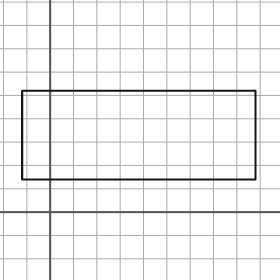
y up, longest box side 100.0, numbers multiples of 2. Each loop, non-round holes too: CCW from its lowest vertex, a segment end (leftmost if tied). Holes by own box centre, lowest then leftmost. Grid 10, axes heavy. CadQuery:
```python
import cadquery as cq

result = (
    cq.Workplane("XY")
    .moveTo(-12.0, 14.0)
    .lineTo(88.0, 14.0)
    .lineTo(88.0, 52.0)
    .lineTo(-12.0, 52.0)
    .close()
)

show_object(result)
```